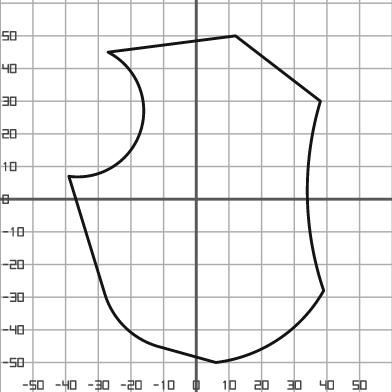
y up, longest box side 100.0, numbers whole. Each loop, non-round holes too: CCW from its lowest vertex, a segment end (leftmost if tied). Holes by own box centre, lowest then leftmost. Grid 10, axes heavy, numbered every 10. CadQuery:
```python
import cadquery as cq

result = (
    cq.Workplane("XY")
    .moveTo(6.0, -50.0)
    .threePointArc((25.0, -43.0), (39.0, -28.0))
    .threePointArc((34.0, 1.0), (38.0, 30.0))
    .lineTo(12.0, 50.0)
    .lineTo(-27.0, 45.0)
    .threePointArc((-17.0, 21.0), (-39.0, 7.0))
    .lineTo(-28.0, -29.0)
    .threePointArc((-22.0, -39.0), (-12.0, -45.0))
    .close()
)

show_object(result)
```